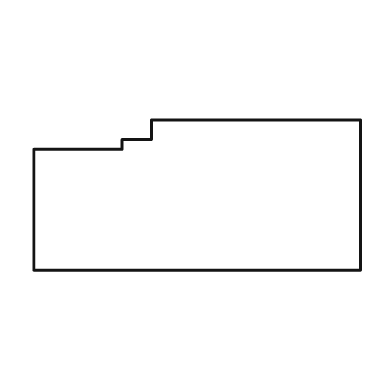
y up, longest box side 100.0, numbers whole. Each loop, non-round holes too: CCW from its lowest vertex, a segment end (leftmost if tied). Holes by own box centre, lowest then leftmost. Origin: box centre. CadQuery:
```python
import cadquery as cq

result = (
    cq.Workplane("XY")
    .moveTo(-50.0, -23.0)
    .lineTo(50.0, -23.0)
    .lineTo(50.0, 23.0)
    .lineTo(-14.0, 23.0)
    .lineTo(-14.0, 17.0)
    .lineTo(-23.0, 17.0)
    .lineTo(-23.0, 14.0)
    .lineTo(-50.0, 14.0)
    .close()
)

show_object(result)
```